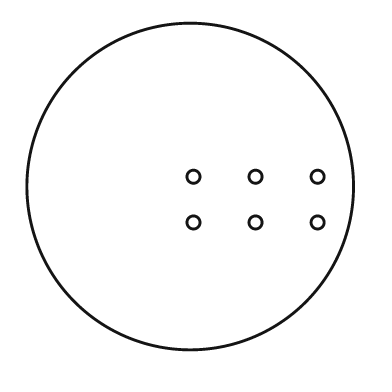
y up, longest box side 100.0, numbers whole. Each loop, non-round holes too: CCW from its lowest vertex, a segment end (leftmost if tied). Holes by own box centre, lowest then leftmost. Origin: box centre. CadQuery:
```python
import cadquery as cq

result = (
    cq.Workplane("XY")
    .moveTo(0.0, 0.0)
    .circle(50.0)
    .moveTo(1.0, -11.0)
    .circle(2.0)
    .moveTo(20.0, -11.0)
    .circle(2.0)
    .moveTo(39.0, -11.0)
    .circle(2.0)
    .moveTo(1.0, 3.0)
    .circle(2.0)
    .moveTo(20.0, 3.0)
    .circle(2.0)
    .moveTo(39.0, 3.0)
    .circle(2.0)
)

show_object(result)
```